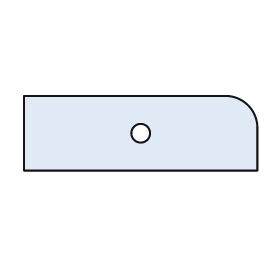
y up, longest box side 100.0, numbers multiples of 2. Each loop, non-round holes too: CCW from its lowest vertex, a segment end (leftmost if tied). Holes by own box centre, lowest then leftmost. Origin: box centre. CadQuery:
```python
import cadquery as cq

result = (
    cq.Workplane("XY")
    .moveTo(-50.0, -16.0)
    .lineTo(50.0, -16.0)
    .lineTo(50.0, 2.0)
    .threePointArc((46.0, 12.0), (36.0, 16.0))
    .lineTo(-50.0, 16.0)
    .close()
    .moveTo(0.0, 0.0)
    .circle(4.0)
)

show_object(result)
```